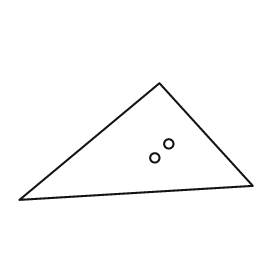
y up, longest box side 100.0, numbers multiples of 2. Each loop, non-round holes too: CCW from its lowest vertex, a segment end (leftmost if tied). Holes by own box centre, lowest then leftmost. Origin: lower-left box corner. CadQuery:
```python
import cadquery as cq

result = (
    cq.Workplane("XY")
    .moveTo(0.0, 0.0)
    .lineTo(100.0, 6.0)
    .lineTo(60.0, 50.0)
    .close()
    .moveTo(58.0, 18.0)
    .circle(2.0)
    .moveTo(64.0, 24.0)
    .circle(2.0)
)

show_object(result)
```